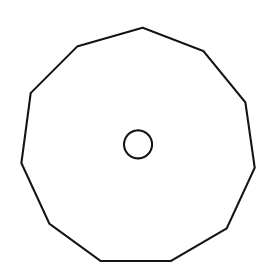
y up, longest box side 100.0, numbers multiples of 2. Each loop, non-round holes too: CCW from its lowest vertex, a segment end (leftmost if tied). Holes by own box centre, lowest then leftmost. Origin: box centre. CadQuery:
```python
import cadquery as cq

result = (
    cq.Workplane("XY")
    .moveTo(-16.0, -50.0)
    .lineTo(14.0, -50.0)
    .lineTo(38.0, -36.0)
    .lineTo(50.0, -10.0)
    .lineTo(46.0, 18.0)
    .lineTo(28.0, 40.0)
    .lineTo(2.0, 50.0)
    .lineTo(-26.0, 42.0)
    .lineTo(-46.0, 22.0)
    .lineTo(-50.0, -8.0)
    .lineTo(-38.0, -34.0)
    .close()
    .moveTo(0.0, 0.0)
    .circle(6.0)
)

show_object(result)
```